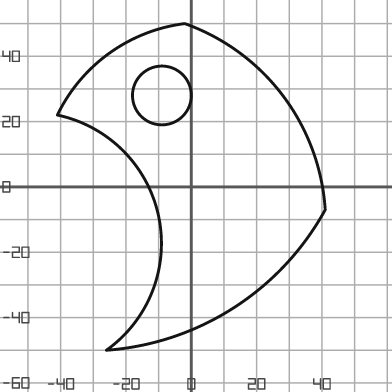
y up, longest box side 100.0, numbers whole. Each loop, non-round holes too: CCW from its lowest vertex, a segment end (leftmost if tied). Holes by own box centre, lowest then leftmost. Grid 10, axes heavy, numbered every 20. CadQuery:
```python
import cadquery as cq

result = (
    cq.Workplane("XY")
    .moveTo(-26.0, -50.0)
    .threePointArc((13.0, -37.0), (41.0, -7.0))
    .threePointArc((28.0, 28.0), (-2.0, 50.0))
    .threePointArc((-25.0, 41.0), (-41.0, 22.0))
    .threePointArc((-10.0, -9.0), (-26.0, -50.0))
    .close()
    .moveTo(-9.0, 28.0)
    .circle(9.0)
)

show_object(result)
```